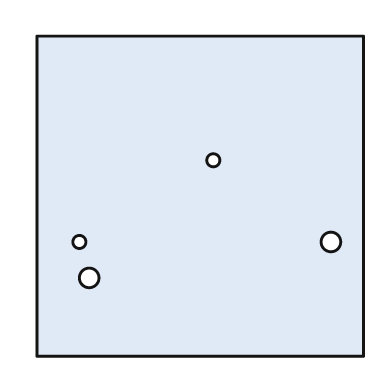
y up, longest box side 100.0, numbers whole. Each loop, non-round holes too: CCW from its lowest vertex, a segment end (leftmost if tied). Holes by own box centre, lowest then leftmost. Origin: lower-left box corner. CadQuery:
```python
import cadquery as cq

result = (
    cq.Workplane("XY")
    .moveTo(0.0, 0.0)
    .lineTo(100.0, 0.0)
    .lineTo(100.0, 98.0)
    .lineTo(0.0, 98.0)
    .close()
    .moveTo(16.0, 24.0)
    .circle(3.0)
    .moveTo(13.0, 35.0)
    .circle(2.0)
    .moveTo(90.0, 35.0)
    .circle(3.0)
    .moveTo(54.0, 60.0)
    .circle(2.0)
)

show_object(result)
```